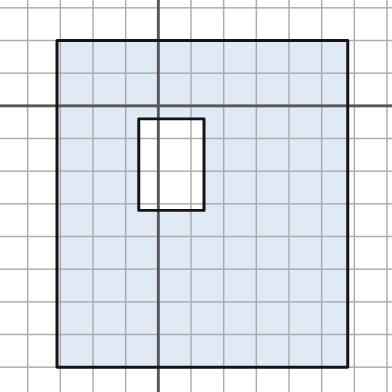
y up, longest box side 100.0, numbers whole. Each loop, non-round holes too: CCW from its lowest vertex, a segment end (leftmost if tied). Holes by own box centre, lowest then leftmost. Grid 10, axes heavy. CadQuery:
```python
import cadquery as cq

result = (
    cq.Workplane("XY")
    .moveTo(-31.0, -80.0)
    .lineTo(58.0, -80.0)
    .lineTo(58.0, 20.0)
    .lineTo(-31.0, 20.0)
    .close()
    .moveTo(-6.0, -32.0)
    .lineTo(14.0, -32.0)
    .lineTo(14.0, -4.0)
    .lineTo(-6.0, -4.0)
    .close()
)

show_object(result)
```